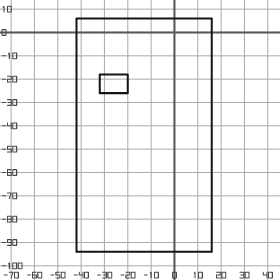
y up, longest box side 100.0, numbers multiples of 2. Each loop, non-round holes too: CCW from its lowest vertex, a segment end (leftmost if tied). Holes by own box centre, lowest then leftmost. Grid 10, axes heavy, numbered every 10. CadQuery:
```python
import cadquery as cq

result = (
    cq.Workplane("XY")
    .moveTo(-42.0, -94.0)
    .lineTo(16.0, -94.0)
    .lineTo(16.0, 6.0)
    .lineTo(-42.0, 6.0)
    .close()
    .moveTo(-32.0, -26.0)
    .lineTo(-20.0, -26.0)
    .lineTo(-20.0, -18.0)
    .lineTo(-32.0, -18.0)
    .close()
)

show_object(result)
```